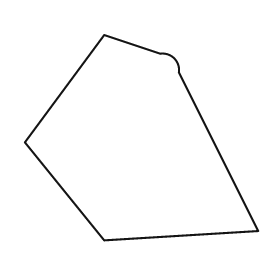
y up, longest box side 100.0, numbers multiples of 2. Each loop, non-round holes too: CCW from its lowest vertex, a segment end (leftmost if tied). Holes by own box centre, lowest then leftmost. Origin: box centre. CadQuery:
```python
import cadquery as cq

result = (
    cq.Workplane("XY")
    .moveTo(-16.0, -44.0)
    .lineTo(50.0, -40.0)
    .lineTo(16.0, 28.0)
    .threePointArc((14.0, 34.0), (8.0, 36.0))
    .lineTo(-16.0, 44.0)
    .lineTo(-50.0, -2.0)
    .close()
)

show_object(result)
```